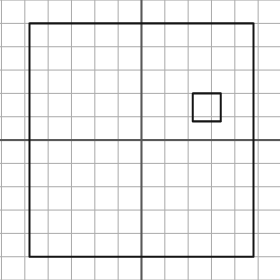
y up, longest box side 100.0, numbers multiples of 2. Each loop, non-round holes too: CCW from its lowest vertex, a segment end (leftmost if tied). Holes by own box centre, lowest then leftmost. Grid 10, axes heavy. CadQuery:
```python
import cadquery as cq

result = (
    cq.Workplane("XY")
    .moveTo(-48.0, -50.0)
    .lineTo(48.0, -50.0)
    .lineTo(48.0, 50.0)
    .lineTo(-48.0, 50.0)
    .close()
    .moveTo(22.0, 8.0)
    .lineTo(34.0, 8.0)
    .lineTo(34.0, 20.0)
    .lineTo(22.0, 20.0)
    .close()
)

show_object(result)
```